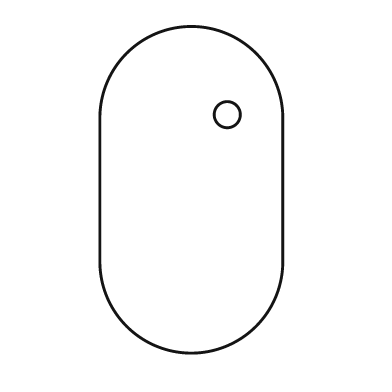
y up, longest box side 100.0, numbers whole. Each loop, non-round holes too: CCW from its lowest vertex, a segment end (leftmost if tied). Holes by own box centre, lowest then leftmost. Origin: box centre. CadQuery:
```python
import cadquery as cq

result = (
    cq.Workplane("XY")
    .moveTo(-28.0, -22.0)
    .threePointArc((0.0, -50.0), (28.0, -22.0))
    .lineTo(28.0, 22.0)
    .threePointArc((0.0, 50.0), (-28.0, 22.0))
    .close()
    .moveTo(11.0, 23.0)
    .circle(4.0)
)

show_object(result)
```